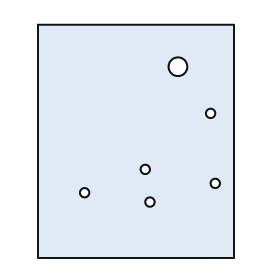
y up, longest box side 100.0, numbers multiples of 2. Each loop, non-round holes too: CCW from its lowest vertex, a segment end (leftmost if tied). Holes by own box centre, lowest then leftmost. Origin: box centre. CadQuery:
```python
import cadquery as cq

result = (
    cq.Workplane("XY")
    .moveTo(-42.0, -50.0)
    .lineTo(42.0, -50.0)
    .lineTo(42.0, 50.0)
    .lineTo(-42.0, 50.0)
    .close()
    .moveTo(6.0, -26.0)
    .circle(2.0)
    .moveTo(-22.0, -22.0)
    .circle(2.0)
    .moveTo(34.0, -18.0)
    .circle(2.0)
    .moveTo(4.0, -12.0)
    .circle(2.0)
    .moveTo(32.0, 12.0)
    .circle(2.0)
    .moveTo(18.0, 32.0)
    .circle(4.0)
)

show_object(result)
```